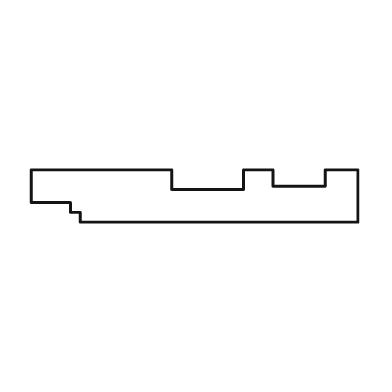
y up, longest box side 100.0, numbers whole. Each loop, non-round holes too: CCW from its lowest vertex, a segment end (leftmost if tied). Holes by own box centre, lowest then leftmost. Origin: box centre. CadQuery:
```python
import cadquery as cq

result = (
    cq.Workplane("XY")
    .moveTo(-35.0, -8.0)
    .lineTo(50.0, -8.0)
    .lineTo(50.0, 8.0)
    .lineTo(40.0, 8.0)
    .lineTo(40.0, 3.0)
    .lineTo(24.0, 3.0)
    .lineTo(24.0, 8.0)
    .lineTo(15.0, 8.0)
    .lineTo(15.0, 2.0)
    .lineTo(-7.0, 2.0)
    .lineTo(-7.0, 8.0)
    .lineTo(-50.0, 8.0)
    .lineTo(-50.0, -2.0)
    .lineTo(-38.0, -2.0)
    .lineTo(-38.0, -5.0)
    .lineTo(-35.0, -5.0)
    .close()
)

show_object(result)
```